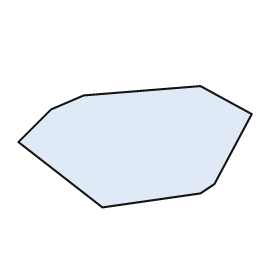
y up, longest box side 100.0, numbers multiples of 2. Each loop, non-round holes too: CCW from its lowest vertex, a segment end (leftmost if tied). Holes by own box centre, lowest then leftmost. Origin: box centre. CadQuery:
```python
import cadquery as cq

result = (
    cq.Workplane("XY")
    .moveTo(-14.0, -26.0)
    .lineTo(28.0, -20.0)
    .lineTo(34.0, -16.0)
    .lineTo(50.0, 14.0)
    .lineTo(28.0, 26.0)
    .lineTo(-22.0, 22.0)
    .lineTo(-36.0, 16.0)
    .lineTo(-50.0, 2.0)
    .close()
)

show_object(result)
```